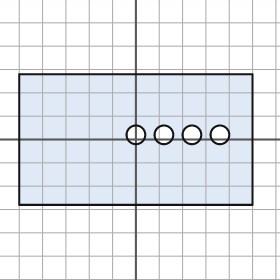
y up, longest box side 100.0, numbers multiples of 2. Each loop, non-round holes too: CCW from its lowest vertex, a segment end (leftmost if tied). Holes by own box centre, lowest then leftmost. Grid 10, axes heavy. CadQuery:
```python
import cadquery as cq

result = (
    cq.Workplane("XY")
    .moveTo(-50.0, -28.0)
    .lineTo(50.0, -28.0)
    .lineTo(50.0, 28.0)
    .lineTo(-50.0, 28.0)
    .close()
    .moveTo(0.0, 2.0)
    .circle(4.0)
    .moveTo(12.0, 2.0)
    .circle(4.0)
    .moveTo(24.0, 2.0)
    .circle(4.0)
    .moveTo(36.0, 2.0)
    .circle(4.0)
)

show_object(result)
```